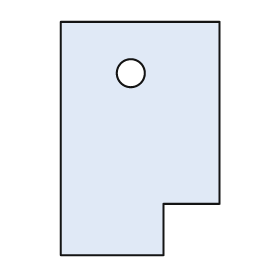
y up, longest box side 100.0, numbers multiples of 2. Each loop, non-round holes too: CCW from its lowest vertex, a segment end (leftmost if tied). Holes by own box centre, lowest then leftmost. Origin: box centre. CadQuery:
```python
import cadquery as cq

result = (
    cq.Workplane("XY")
    .moveTo(-34.0, -50.0)
    .lineTo(10.0, -50.0)
    .lineTo(10.0, -28.0)
    .lineTo(34.0, -28.0)
    .lineTo(34.0, 50.0)
    .lineTo(-34.0, 50.0)
    .close()
    .moveTo(-4.0, 28.0)
    .circle(6.0)
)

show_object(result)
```